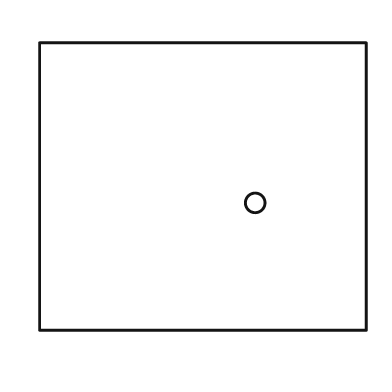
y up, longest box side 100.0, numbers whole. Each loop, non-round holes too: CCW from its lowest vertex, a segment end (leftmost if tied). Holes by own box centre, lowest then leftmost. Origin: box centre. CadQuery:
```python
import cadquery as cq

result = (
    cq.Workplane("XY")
    .moveTo(-50.0, -44.0)
    .lineTo(50.0, -44.0)
    .lineTo(50.0, 44.0)
    .lineTo(-50.0, 44.0)
    .close()
    .moveTo(16.0, -5.0)
    .circle(3.0)
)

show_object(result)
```